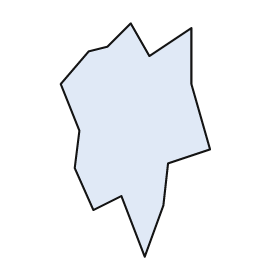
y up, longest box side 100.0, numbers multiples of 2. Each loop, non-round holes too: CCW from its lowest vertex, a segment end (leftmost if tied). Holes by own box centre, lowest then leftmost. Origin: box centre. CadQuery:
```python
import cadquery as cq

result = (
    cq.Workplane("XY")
    .moveTo(4.0, -50.0)
    .lineTo(12.0, -28.0)
    .lineTo(14.0, -10.0)
    .lineTo(32.0, -4.0)
    .lineTo(24.0, 24.0)
    .lineTo(24.0, 48.0)
    .lineTo(6.0, 36.0)
    .lineTo(-2.0, 50.0)
    .lineTo(-12.0, 40.0)
    .lineTo(-20.0, 38.0)
    .lineTo(-32.0, 24.0)
    .lineTo(-24.0, 4.0)
    .lineTo(-26.0, -12.0)
    .lineTo(-18.0, -30.0)
    .lineTo(-6.0, -24.0)
    .close()
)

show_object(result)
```